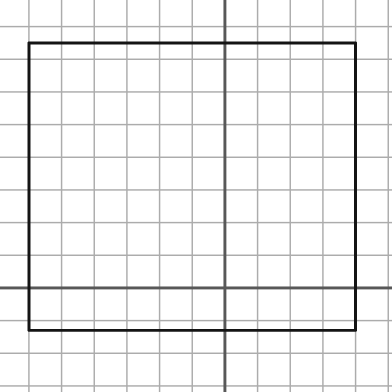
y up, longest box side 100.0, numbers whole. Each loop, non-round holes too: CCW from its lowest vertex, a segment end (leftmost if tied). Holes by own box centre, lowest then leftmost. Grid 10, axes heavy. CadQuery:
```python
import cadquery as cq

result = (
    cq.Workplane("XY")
    .moveTo(-60.0, -13.0)
    .lineTo(40.0, -13.0)
    .lineTo(40.0, 75.0)
    .lineTo(-60.0, 75.0)
    .close()
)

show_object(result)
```